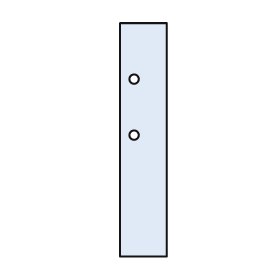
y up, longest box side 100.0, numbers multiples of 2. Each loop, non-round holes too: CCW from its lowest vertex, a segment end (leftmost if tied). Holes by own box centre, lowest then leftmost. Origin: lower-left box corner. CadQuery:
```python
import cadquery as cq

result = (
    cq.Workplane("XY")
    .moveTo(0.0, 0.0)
    .lineTo(20.0, 0.0)
    .lineTo(20.0, 100.0)
    .lineTo(0.0, 100.0)
    .close()
    .moveTo(6.0, 52.0)
    .circle(2.0)
    .moveTo(6.0, 76.0)
    .circle(2.0)
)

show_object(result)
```